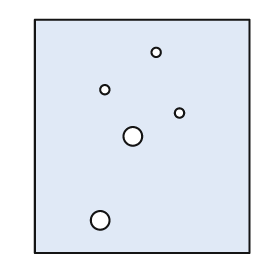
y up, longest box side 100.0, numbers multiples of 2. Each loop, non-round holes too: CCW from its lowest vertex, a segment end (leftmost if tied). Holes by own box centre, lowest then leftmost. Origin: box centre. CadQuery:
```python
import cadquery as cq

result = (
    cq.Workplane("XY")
    .moveTo(-46.0, -50.0)
    .lineTo(46.0, -50.0)
    .lineTo(46.0, 50.0)
    .lineTo(-46.0, 50.0)
    .close()
    .moveTo(-18.0, -36.0)
    .circle(4.0)
    .moveTo(-4.0, 0.0)
    .circle(4.0)
    .moveTo(16.0, 10.0)
    .circle(2.0)
    .moveTo(-16.0, 20.0)
    .circle(2.0)
    .moveTo(6.0, 36.0)
    .circle(2.0)
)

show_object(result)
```